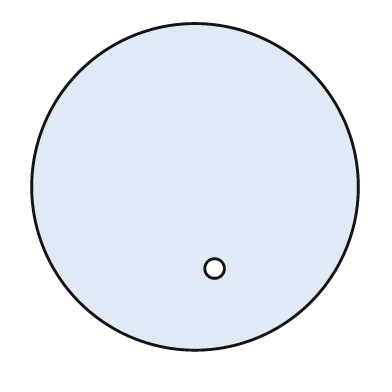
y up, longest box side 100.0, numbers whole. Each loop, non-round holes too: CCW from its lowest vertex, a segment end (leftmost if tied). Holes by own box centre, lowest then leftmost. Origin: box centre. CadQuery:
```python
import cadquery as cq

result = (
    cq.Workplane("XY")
    .moveTo(0.0, 0.0)
    .circle(50.0)
    .moveTo(6.0, -25.0)
    .circle(3.0)
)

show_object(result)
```